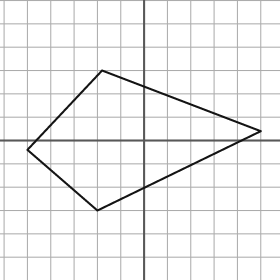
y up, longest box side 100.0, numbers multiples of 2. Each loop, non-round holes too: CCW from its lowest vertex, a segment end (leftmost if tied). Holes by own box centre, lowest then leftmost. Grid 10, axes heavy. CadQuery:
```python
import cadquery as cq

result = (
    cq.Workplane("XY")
    .moveTo(-20.0, -30.0)
    .lineTo(50.0, 4.0)
    .lineTo(-18.0, 30.0)
    .lineTo(-50.0, -4.0)
    .close()
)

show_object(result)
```